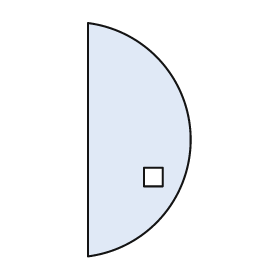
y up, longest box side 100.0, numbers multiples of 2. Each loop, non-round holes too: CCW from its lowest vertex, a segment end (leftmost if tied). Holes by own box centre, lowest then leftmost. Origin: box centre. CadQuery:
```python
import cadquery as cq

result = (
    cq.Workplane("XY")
    .moveTo(-22.0, -50.0)
    .threePointArc((22.0, 0.0), (-22.0, 50.0))
    .close()
    .moveTo(2.0, -20.0)
    .lineTo(10.0, -20.0)
    .lineTo(10.0, -12.0)
    .lineTo(2.0, -12.0)
    .close()
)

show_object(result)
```